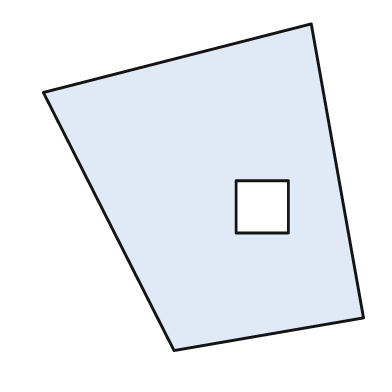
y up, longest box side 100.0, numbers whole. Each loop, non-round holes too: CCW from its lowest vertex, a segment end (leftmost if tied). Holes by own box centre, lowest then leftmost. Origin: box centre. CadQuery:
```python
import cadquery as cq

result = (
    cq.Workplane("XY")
    .moveTo(-9.0, -50.0)
    .lineTo(49.0, -40.0)
    .lineTo(33.0, 50.0)
    .lineTo(-49.0, 29.0)
    .close()
    .moveTo(10.0, -14.0)
    .lineTo(26.0, -14.0)
    .lineTo(26.0, 2.0)
    .lineTo(10.0, 2.0)
    .close()
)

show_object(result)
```